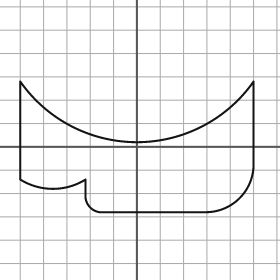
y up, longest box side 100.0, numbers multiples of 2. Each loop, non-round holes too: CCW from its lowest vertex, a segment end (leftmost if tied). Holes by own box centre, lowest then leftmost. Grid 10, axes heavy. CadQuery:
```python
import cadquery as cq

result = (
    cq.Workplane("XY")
    .moveTo(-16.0, -28.0)
    .lineTo(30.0, -28.0)
    .threePointArc((44.0, -22.0), (50.0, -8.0))
    .lineTo(50.0, 28.0)
    .threePointArc((0.0, 2.0), (-50.0, 28.0))
    .lineTo(-50.0, -14.0)
    .threePointArc((-36.0, -18.0), (-22.0, -14.0))
    .lineTo(-22.0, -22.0)
    .threePointArc((-20.0, -26.0), (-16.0, -28.0))
    .close()
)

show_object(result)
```